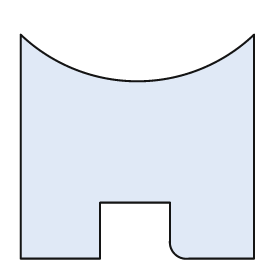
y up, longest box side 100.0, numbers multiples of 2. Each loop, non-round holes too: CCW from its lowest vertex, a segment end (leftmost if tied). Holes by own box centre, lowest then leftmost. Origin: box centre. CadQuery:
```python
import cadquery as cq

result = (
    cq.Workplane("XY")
    .moveTo(-50.0, -48.0)
    .lineTo(-16.0, -48.0)
    .lineTo(-16.0, -24.0)
    .lineTo(14.0, -24.0)
    .lineTo(14.0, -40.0)
    .threePointArc((16.0, -46.0), (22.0, -48.0))
    .lineTo(50.0, -48.0)
    .lineTo(50.0, 48.0)
    .threePointArc((0.0, 28.0), (-50.0, 48.0))
    .close()
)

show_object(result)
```